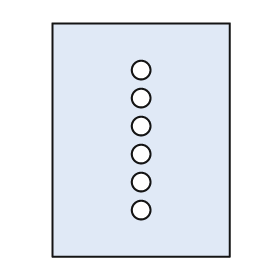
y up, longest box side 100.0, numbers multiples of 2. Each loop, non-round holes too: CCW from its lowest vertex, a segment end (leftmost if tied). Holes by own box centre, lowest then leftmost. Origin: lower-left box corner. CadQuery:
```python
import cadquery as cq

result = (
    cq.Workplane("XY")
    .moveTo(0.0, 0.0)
    .lineTo(76.0, 0.0)
    .lineTo(76.0, 100.0)
    .lineTo(0.0, 100.0)
    .close()
    .moveTo(38.0, 20.0)
    .circle(4.0)
    .moveTo(38.0, 32.0)
    .circle(4.0)
    .moveTo(38.0, 44.0)
    .circle(4.0)
    .moveTo(38.0, 56.0)
    .circle(4.0)
    .moveTo(38.0, 68.0)
    .circle(4.0)
    .moveTo(38.0, 80.0)
    .circle(4.0)
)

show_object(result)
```